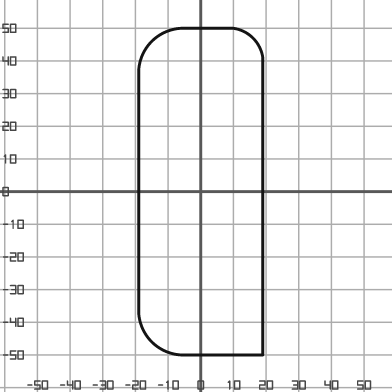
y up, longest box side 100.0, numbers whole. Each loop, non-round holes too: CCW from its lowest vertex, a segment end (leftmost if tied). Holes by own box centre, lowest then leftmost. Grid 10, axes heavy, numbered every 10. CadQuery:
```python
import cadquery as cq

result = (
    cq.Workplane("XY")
    .moveTo(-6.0, -50.0)
    .lineTo(19.0, -50.0)
    .lineTo(19.0, 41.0)
    .threePointArc((16.0, 47.0), (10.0, 50.0))
    .lineTo(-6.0, 50.0)
    .threePointArc((-15.0, 46.0), (-19.0, 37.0))
    .lineTo(-19.0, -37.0)
    .threePointArc((-15.0, -46.0), (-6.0, -50.0))
    .close()
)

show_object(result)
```